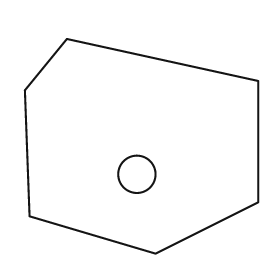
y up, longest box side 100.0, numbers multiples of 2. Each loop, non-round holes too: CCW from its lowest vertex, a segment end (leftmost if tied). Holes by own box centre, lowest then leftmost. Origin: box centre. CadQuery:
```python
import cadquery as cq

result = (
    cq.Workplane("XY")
    .moveTo(6.0, -46.0)
    .lineTo(50.0, -24.0)
    .lineTo(50.0, 28.0)
    .lineTo(-32.0, 46.0)
    .lineTo(-50.0, 24.0)
    .lineTo(-48.0, -30.0)
    .close()
    .moveTo(-2.0, -12.0)
    .circle(8.0)
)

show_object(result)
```